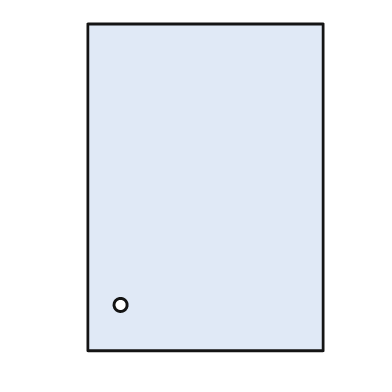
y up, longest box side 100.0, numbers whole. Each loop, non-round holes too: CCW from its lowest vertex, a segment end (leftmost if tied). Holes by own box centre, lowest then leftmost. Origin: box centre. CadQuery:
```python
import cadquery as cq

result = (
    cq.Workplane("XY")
    .moveTo(-36.0, -50.0)
    .lineTo(36.0, -50.0)
    .lineTo(36.0, 50.0)
    .lineTo(-36.0, 50.0)
    .close()
    .moveTo(-26.0, -36.0)
    .circle(2.0)
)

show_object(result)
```